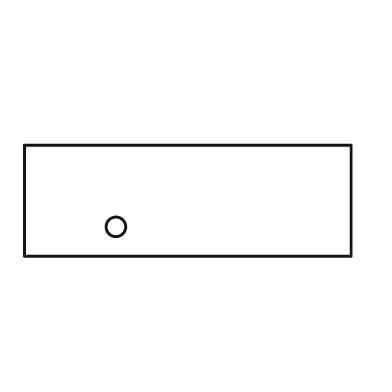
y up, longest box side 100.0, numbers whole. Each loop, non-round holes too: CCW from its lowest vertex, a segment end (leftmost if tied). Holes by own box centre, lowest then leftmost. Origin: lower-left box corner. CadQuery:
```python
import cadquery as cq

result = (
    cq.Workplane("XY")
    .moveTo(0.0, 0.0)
    .lineTo(100.0, 0.0)
    .lineTo(100.0, 34.0)
    .lineTo(0.0, 34.0)
    .close()
    .moveTo(28.0, 9.0)
    .circle(3.0)
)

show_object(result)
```